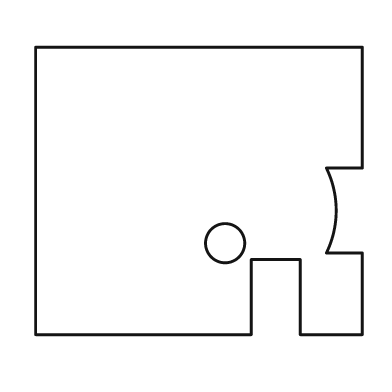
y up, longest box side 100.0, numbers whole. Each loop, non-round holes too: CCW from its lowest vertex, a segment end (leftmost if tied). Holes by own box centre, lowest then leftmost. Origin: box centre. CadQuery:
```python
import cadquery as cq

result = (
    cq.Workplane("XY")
    .moveTo(-50.0, -44.0)
    .lineTo(16.0, -44.0)
    .lineTo(16.0, -21.0)
    .lineTo(31.0, -21.0)
    .lineTo(31.0, -44.0)
    .lineTo(50.0, -44.0)
    .lineTo(50.0, -19.0)
    .lineTo(39.0, -19.0)
    .threePointArc((42.0, -6.0), (39.0, 7.0))
    .lineTo(50.0, 7.0)
    .lineTo(50.0, 44.0)
    .lineTo(-50.0, 44.0)
    .close()
    .moveTo(8.0, -16.0)
    .circle(6.0)
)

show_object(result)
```